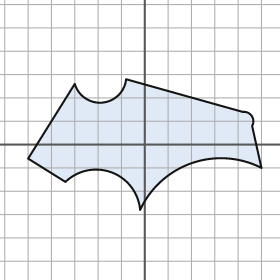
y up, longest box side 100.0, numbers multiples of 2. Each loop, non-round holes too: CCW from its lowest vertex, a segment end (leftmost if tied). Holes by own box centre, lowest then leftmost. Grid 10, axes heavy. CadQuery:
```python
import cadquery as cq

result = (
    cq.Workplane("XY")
    .moveTo(-2.0, -28.0)
    .threePointArc((20.0, -8.0), (50.0, -10.0))
    .lineTo(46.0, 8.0)
    .threePointArc((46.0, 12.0), (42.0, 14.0))
    .lineTo(-8.0, 28.0)
    .threePointArc((-18.0, 18.0), (-30.0, 26.0))
    .lineTo(-50.0, -6.0)
    .lineTo(-34.0, -16.0)
    .threePointArc((-14.0, -12.0), (-2.0, -28.0))
    .close()
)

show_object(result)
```